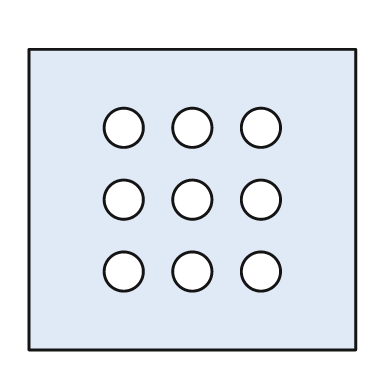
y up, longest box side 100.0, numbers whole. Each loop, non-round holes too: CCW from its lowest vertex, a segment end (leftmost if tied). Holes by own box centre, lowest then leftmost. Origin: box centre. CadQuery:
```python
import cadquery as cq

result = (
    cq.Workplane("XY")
    .moveTo(-50.0, -46.0)
    .lineTo(50.0, -46.0)
    .lineTo(50.0, 46.0)
    .lineTo(-50.0, 46.0)
    .close()
    .moveTo(-21.0, -22.0)
    .circle(6.0)
    .moveTo(0.0, -22.0)
    .circle(6.0)
    .moveTo(21.0, -22.0)
    .circle(6.0)
    .moveTo(-21.0, 0.0)
    .circle(6.0)
    .moveTo(0.0, 0.0)
    .circle(6.0)
    .moveTo(21.0, 0.0)
    .circle(6.0)
    .moveTo(-21.0, 22.0)
    .circle(6.0)
    .moveTo(0.0, 22.0)
    .circle(6.0)
    .moveTo(21.0, 22.0)
    .circle(6.0)
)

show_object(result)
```